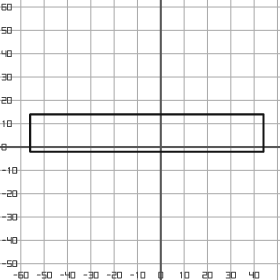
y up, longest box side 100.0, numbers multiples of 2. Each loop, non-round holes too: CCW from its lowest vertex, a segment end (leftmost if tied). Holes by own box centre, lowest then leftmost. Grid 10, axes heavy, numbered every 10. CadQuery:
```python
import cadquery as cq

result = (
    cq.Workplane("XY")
    .moveTo(-56.0, -2.0)
    .lineTo(44.0, -2.0)
    .lineTo(44.0, 14.0)
    .lineTo(-56.0, 14.0)
    .close()
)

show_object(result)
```